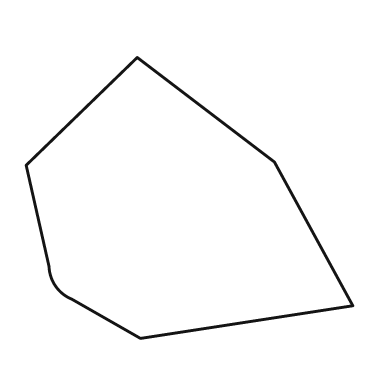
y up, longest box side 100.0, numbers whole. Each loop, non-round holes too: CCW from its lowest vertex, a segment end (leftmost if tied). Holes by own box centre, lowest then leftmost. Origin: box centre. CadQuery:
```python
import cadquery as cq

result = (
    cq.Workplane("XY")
    .moveTo(-15.0, -43.0)
    .lineTo(50.0, -33.0)
    .lineTo(26.0, 11.0)
    .lineTo(-16.0, 43.0)
    .lineTo(-50.0, 10.0)
    .lineTo(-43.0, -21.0)
    .threePointArc((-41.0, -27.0), (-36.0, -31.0))
    .close()
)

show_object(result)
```